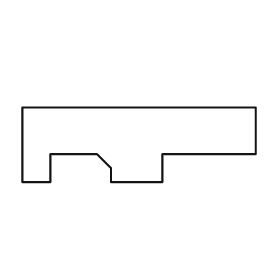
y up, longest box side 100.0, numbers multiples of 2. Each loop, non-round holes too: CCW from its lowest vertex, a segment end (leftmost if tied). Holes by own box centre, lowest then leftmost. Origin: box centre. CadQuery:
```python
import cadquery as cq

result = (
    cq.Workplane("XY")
    .moveTo(-50.0, -16.0)
    .lineTo(-38.0, -16.0)
    .lineTo(-38.0, -4.0)
    .lineTo(-18.0, -4.0)
    .lineTo(-12.0, -10.0)
    .lineTo(-12.0, -16.0)
    .lineTo(10.0, -16.0)
    .lineTo(10.0, -4.0)
    .lineTo(50.0, -4.0)
    .lineTo(50.0, 16.0)
    .lineTo(-50.0, 16.0)
    .close()
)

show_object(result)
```